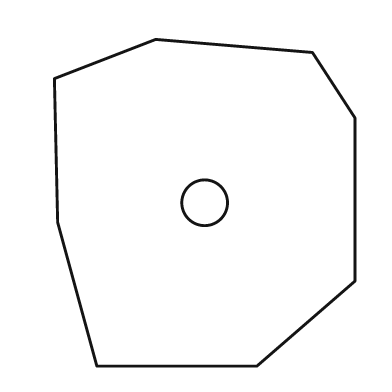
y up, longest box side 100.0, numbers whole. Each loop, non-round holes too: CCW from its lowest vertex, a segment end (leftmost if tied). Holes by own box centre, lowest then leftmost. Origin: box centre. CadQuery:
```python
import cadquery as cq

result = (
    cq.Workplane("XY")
    .moveTo(-33.0, -50.0)
    .lineTo(16.0, -50.0)
    .lineTo(46.0, -24.0)
    .lineTo(46.0, 26.0)
    .lineTo(33.0, 46.0)
    .lineTo(-15.0, 50.0)
    .lineTo(-46.0, 38.0)
    .lineTo(-45.0, -6.0)
    .close()
    .moveTo(0.0, 0.0)
    .circle(7.0)
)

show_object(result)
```